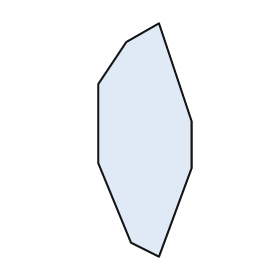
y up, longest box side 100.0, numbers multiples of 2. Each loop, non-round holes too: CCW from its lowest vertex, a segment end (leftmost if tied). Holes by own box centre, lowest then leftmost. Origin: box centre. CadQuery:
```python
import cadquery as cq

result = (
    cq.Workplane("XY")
    .moveTo(6.0, -50.0)
    .lineTo(20.0, -12.0)
    .lineTo(20.0, 8.0)
    .lineTo(6.0, 50.0)
    .lineTo(-8.0, 42.0)
    .lineTo(-20.0, 24.0)
    .lineTo(-20.0, -10.0)
    .lineTo(-6.0, -44.0)
    .close()
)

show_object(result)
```